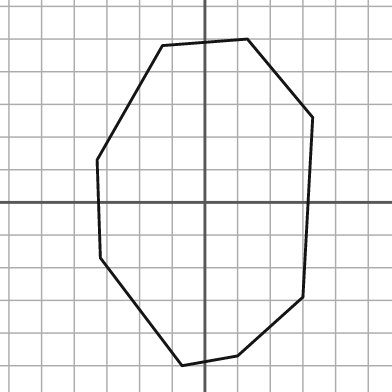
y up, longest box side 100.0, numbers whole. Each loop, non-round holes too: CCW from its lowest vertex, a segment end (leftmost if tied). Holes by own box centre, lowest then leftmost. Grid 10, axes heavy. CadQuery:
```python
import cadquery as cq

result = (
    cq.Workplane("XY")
    .moveTo(-7.0, -50.0)
    .lineTo(10.0, -47.0)
    .lineTo(30.0, -29.0)
    .lineTo(33.0, 26.0)
    .lineTo(13.0, 50.0)
    .lineTo(-13.0, 48.0)
    .lineTo(-33.0, 13.0)
    .lineTo(-32.0, -17.0)
    .close()
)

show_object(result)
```